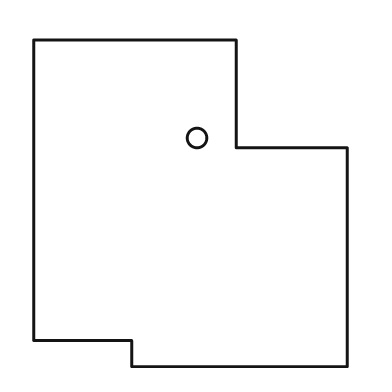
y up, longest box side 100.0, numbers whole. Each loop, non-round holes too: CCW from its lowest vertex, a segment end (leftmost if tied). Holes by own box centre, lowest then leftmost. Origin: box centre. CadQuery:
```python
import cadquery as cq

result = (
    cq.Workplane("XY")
    .moveTo(-18.0, -50.0)
    .lineTo(48.0, -50.0)
    .lineTo(48.0, 17.0)
    .lineTo(14.0, 17.0)
    .lineTo(14.0, 50.0)
    .lineTo(-48.0, 50.0)
    .lineTo(-48.0, -42.0)
    .lineTo(-18.0, -42.0)
    .close()
    .moveTo(2.0, 20.0)
    .circle(3.0)
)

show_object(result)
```